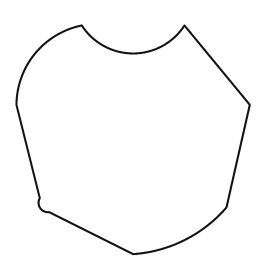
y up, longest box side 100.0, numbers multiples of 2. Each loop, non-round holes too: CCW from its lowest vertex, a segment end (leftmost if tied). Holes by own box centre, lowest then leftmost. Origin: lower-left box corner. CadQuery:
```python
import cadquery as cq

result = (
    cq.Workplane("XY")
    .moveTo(50.0, 0.0)
    .threePointArc((72.0, 6.0), (90.0, 20.0))
    .lineTo(100.0, 64.0)
    .lineTo(72.0, 98.0)
    .threePointArc((50.0, 86.0), (28.0, 98.0))
    .threePointArc((8.0, 86.0), (0.0, 64.0))
    .lineTo(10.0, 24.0)
    .threePointArc((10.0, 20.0), (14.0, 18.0))
    .close()
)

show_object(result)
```